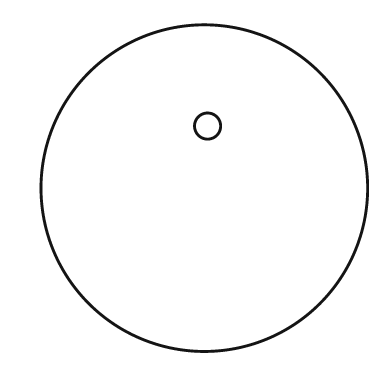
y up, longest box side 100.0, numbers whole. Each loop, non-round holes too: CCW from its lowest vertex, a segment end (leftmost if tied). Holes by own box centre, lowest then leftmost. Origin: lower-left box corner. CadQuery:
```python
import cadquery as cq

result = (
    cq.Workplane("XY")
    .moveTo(50.0, 50.0)
    .circle(50.0)
    .moveTo(51.0, 69.0)
    .circle(4.0)
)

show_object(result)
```